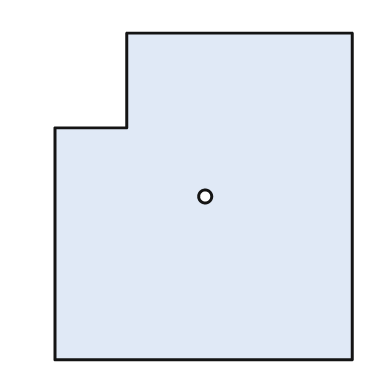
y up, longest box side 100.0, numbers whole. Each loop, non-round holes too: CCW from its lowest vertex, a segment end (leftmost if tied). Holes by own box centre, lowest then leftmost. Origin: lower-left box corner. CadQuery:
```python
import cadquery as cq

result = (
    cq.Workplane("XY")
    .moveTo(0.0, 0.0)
    .lineTo(91.0, 0.0)
    .lineTo(91.0, 100.0)
    .lineTo(22.0, 100.0)
    .lineTo(22.0, 71.0)
    .lineTo(0.0, 71.0)
    .close()
    .moveTo(46.0, 50.0)
    .circle(2.0)
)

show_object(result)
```